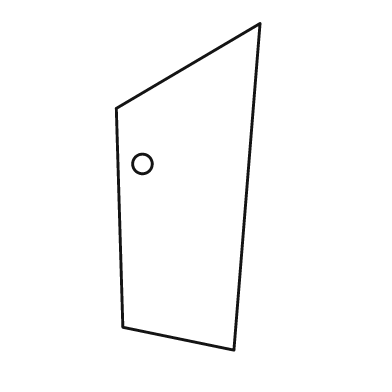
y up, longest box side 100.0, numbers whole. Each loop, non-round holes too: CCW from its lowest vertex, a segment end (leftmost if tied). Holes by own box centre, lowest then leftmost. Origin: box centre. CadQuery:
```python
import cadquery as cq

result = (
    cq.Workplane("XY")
    .moveTo(14.0, -50.0)
    .lineTo(22.0, 50.0)
    .lineTo(-22.0, 24.0)
    .lineTo(-20.0, -43.0)
    .close()
    .moveTo(-14.0, 7.0)
    .circle(3.0)
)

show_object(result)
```